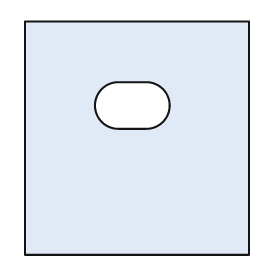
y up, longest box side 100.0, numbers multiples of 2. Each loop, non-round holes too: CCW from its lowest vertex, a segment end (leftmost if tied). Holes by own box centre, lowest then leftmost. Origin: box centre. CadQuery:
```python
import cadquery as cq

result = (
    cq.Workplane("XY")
    .moveTo(-48.0, -50.0)
    .lineTo(48.0, -50.0)
    .lineTo(48.0, 50.0)
    .lineTo(-48.0, 50.0)
    .close()
    .moveTo(-8.0, 4.0)
    .lineTo(4.0, 4.0)
    .threePointArc((14.0, 14.0), (4.0, 24.0))
    .lineTo(-8.0, 24.0)
    .threePointArc((-18.0, 14.0), (-8.0, 4.0))
    .close()
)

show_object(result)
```